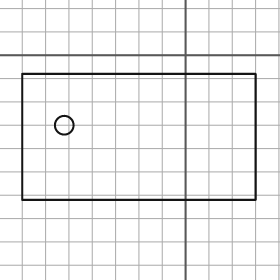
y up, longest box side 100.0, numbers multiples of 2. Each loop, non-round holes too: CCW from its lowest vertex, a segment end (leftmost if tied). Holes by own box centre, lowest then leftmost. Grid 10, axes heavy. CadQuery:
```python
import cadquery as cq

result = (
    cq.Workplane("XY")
    .moveTo(-70.0, -62.0)
    .lineTo(30.0, -62.0)
    .lineTo(30.0, -8.0)
    .lineTo(-70.0, -8.0)
    .close()
    .moveTo(-52.0, -30.0)
    .circle(4.0)
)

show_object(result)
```